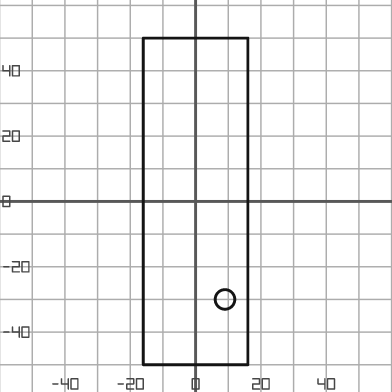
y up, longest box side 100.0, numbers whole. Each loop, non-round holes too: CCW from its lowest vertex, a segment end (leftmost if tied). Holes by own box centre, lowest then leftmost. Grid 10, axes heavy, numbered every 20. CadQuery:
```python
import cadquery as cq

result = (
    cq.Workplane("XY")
    .moveTo(-16.0, -50.0)
    .lineTo(16.0, -50.0)
    .lineTo(16.0, 50.0)
    .lineTo(-16.0, 50.0)
    .close()
    .moveTo(9.0, -30.0)
    .circle(3.0)
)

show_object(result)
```